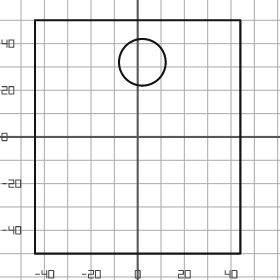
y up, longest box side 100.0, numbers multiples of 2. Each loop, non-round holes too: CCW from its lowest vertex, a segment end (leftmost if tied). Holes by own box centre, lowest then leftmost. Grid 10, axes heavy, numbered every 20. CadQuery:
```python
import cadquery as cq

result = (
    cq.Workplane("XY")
    .moveTo(-44.0, -50.0)
    .lineTo(44.0, -50.0)
    .lineTo(44.0, 50.0)
    .lineTo(-44.0, 50.0)
    .close()
    .moveTo(2.0, 32.0)
    .circle(10.0)
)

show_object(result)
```